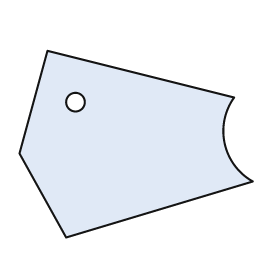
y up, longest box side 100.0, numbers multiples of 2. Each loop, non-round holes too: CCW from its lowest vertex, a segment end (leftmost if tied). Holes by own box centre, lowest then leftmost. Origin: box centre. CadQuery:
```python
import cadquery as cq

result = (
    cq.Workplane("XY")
    .moveTo(-30.0, -40.0)
    .lineTo(50.0, -16.0)
    .threePointArc((38.0, 0.0), (42.0, 20.0))
    .lineTo(-38.0, 40.0)
    .lineTo(-50.0, -4.0)
    .close()
    .moveTo(-26.0, 18.0)
    .circle(4.0)
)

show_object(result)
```